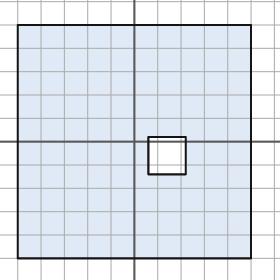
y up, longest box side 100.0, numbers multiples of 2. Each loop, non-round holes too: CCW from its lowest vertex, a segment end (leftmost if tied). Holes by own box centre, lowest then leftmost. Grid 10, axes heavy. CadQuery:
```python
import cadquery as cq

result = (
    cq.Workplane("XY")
    .moveTo(-50.0, -50.0)
    .lineTo(50.0, -50.0)
    .lineTo(50.0, 50.0)
    .lineTo(-50.0, 50.0)
    .close()
    .moveTo(6.0, -14.0)
    .lineTo(22.0, -14.0)
    .lineTo(22.0, 2.0)
    .lineTo(6.0, 2.0)
    .close()
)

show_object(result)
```